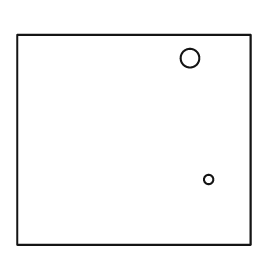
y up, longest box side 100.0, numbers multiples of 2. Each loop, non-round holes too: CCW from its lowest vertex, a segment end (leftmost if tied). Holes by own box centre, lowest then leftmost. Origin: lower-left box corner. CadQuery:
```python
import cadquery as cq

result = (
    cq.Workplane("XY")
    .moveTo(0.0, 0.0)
    .lineTo(100.0, 0.0)
    .lineTo(100.0, 90.0)
    .lineTo(0.0, 90.0)
    .close()
    .moveTo(82.0, 28.0)
    .circle(2.0)
    .moveTo(74.0, 80.0)
    .circle(4.0)
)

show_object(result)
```